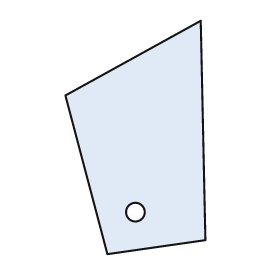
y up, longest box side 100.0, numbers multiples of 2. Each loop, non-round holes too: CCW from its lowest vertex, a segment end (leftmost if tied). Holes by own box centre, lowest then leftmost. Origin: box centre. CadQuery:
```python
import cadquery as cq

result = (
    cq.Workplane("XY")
    .moveTo(-12.0, -50.0)
    .lineTo(30.0, -44.0)
    .lineTo(28.0, 50.0)
    .lineTo(-30.0, 18.0)
    .close()
    .moveTo(0.0, -32.0)
    .circle(4.0)
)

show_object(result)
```